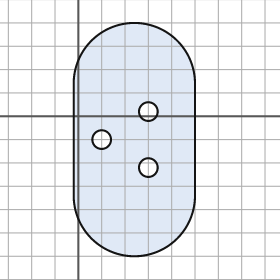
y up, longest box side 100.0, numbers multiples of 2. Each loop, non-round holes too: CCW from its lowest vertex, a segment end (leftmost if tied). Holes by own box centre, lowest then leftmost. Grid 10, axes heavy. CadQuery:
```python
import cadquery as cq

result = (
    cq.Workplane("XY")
    .moveTo(-2.0, -34.0)
    .threePointArc((24.0, -60.0), (50.0, -34.0))
    .lineTo(50.0, 14.0)
    .threePointArc((24.0, 40.0), (-2.0, 14.0))
    .close()
    .moveTo(30.0, -22.0)
    .circle(4.0)
    .moveTo(10.0, -10.0)
    .circle(4.0)
    .moveTo(30.0, 2.0)
    .circle(4.0)
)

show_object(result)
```